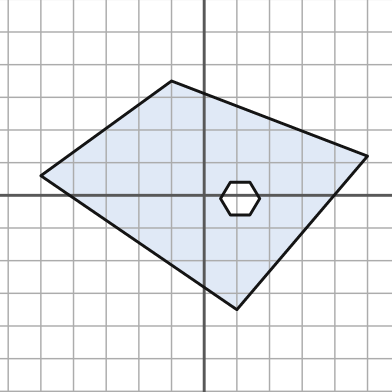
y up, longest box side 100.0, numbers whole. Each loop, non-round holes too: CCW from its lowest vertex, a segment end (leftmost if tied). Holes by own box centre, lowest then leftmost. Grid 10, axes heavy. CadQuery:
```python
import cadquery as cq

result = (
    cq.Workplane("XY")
    .moveTo(10.0, -35.0)
    .lineTo(50.0, 12.0)
    .lineTo(-10.0, 35.0)
    .lineTo(-50.0, 6.0)
    .close()
    .moveTo(8.0, -6.0)
    .lineTo(14.0, -6.0)
    .lineTo(17.0, -1.0)
    .lineTo(14.0, 4.0)
    .lineTo(8.0, 4.0)
    .lineTo(5.0, -1.0)
    .close()
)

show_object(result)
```